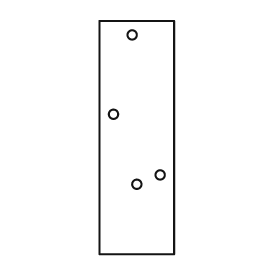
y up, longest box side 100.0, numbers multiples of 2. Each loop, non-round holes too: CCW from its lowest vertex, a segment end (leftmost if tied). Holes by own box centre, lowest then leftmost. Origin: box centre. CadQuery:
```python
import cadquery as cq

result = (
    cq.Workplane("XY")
    .moveTo(-16.0, -50.0)
    .lineTo(16.0, -50.0)
    .lineTo(16.0, 50.0)
    .lineTo(-16.0, 50.0)
    .close()
    .moveTo(0.0, -20.0)
    .circle(2.0)
    .moveTo(10.0, -16.0)
    .circle(2.0)
    .moveTo(-10.0, 10.0)
    .circle(2.0)
    .moveTo(-2.0, 44.0)
    .circle(2.0)
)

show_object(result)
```